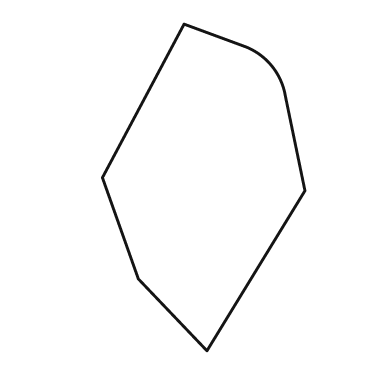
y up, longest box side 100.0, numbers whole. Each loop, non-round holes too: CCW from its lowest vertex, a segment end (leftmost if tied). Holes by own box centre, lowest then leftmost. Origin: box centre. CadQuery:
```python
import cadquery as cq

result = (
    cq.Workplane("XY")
    .moveTo(1.0, -50.0)
    .lineTo(31.0, -1.0)
    .lineTo(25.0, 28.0)
    .threePointArc((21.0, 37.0), (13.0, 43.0))
    .lineTo(-6.0, 50.0)
    .lineTo(-31.0, 3.0)
    .lineTo(-20.0, -28.0)
    .close()
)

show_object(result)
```